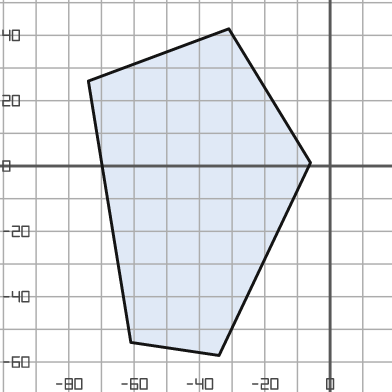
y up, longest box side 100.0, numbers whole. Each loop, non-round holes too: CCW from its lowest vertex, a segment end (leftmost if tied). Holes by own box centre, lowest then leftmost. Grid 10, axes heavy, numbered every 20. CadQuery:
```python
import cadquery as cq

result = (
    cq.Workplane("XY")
    .moveTo(-34.0, -58.0)
    .lineTo(-6.0, 1.0)
    .lineTo(-31.0, 42.0)
    .lineTo(-74.0, 26.0)
    .lineTo(-61.0, -54.0)
    .close()
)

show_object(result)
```